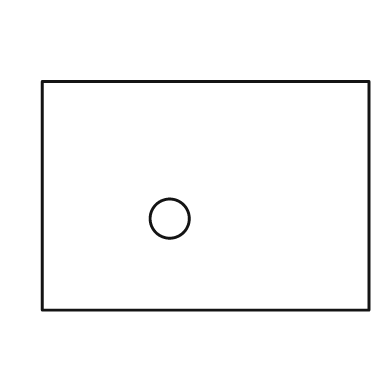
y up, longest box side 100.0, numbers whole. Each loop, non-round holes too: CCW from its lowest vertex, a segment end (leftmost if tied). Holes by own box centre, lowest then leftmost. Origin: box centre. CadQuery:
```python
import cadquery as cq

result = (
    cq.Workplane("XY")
    .moveTo(-50.0, -35.0)
    .lineTo(50.0, -35.0)
    .lineTo(50.0, 35.0)
    .lineTo(-50.0, 35.0)
    .close()
    .moveTo(-11.0, -7.0)
    .circle(6.0)
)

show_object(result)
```